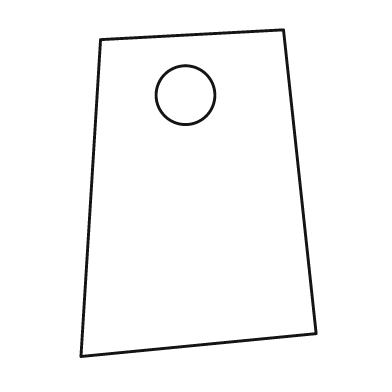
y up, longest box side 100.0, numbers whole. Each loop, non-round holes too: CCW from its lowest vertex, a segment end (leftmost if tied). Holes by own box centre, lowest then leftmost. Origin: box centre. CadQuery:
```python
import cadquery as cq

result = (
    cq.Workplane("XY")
    .moveTo(-36.0, -50.0)
    .lineTo(36.0, -43.0)
    .lineTo(26.0, 50.0)
    .lineTo(-30.0, 47.0)
    .close()
    .moveTo(-4.0, 30.0)
    .circle(9.0)
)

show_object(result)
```